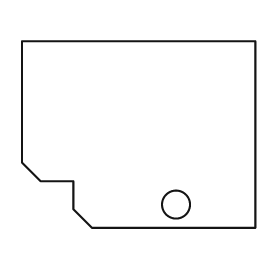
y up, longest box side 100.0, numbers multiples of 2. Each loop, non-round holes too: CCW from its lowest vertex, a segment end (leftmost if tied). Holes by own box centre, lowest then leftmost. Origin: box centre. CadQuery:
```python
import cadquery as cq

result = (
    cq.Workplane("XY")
    .moveTo(-20.0, -40.0)
    .lineTo(50.0, -40.0)
    .lineTo(50.0, 40.0)
    .lineTo(-50.0, 40.0)
    .lineTo(-50.0, -12.0)
    .lineTo(-42.0, -20.0)
    .lineTo(-28.0, -20.0)
    .lineTo(-28.0, -32.0)
    .close()
    .moveTo(16.0, -30.0)
    .circle(6.0)
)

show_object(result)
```